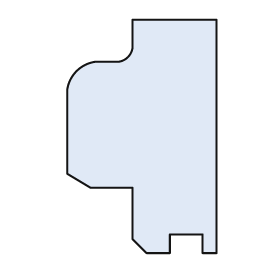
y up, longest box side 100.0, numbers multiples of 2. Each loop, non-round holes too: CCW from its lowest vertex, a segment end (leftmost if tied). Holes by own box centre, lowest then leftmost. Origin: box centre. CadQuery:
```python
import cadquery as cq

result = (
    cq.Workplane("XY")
    .moveTo(2.0, -50.0)
    .lineTo(12.0, -50.0)
    .lineTo(12.0, -42.0)
    .lineTo(26.0, -42.0)
    .lineTo(26.0, -50.0)
    .lineTo(32.0, -50.0)
    .lineTo(32.0, 50.0)
    .lineTo(-4.0, 50.0)
    .lineTo(-4.0, 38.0)
    .threePointArc((-6.0, 34.0), (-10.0, 32.0))
    .lineTo(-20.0, 32.0)
    .threePointArc((-28.0, 28.0), (-32.0, 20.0))
    .lineTo(-32.0, -16.0)
    .lineTo(-22.0, -22.0)
    .lineTo(-4.0, -22.0)
    .lineTo(-4.0, -44.0)
    .close()
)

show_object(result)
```